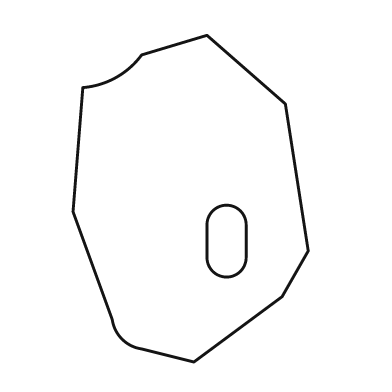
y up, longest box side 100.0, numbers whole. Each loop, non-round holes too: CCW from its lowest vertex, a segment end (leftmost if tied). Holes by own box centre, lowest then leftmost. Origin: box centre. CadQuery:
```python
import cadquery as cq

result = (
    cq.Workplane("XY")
    .moveTo(1.0, -50.0)
    .lineTo(28.0, -30.0)
    .lineTo(36.0, -16.0)
    .lineTo(29.0, 29.0)
    .lineTo(5.0, 50.0)
    .lineTo(-15.0, 44.0)
    .threePointArc((-23.0, 37.0), (-33.0, 34.0))
    .lineTo(-36.0, -4.0)
    .lineTo(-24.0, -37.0)
    .threePointArc((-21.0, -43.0), (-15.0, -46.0))
    .close()
    .moveTo(5.0, -18.0)
    .threePointArc((11.0, -24.0), (17.0, -18.0))
    .lineTo(17.0, -8.0)
    .threePointArc((11.0, -2.0), (5.0, -8.0))
    .close()
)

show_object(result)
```